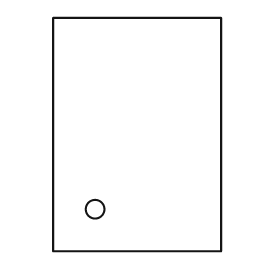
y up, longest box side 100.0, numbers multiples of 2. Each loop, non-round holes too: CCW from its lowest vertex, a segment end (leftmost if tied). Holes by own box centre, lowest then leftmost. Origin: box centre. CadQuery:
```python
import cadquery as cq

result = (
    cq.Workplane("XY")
    .moveTo(-36.0, -50.0)
    .lineTo(36.0, -50.0)
    .lineTo(36.0, 50.0)
    .lineTo(-36.0, 50.0)
    .close()
    .moveTo(-18.0, -32.0)
    .circle(4.0)
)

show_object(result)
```